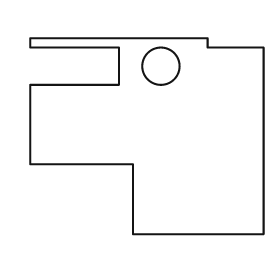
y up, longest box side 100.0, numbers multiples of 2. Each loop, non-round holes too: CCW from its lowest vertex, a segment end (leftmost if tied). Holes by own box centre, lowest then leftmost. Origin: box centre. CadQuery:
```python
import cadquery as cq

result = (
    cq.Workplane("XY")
    .moveTo(-6.0, -42.0)
    .lineTo(50.0, -42.0)
    .lineTo(50.0, 38.0)
    .lineTo(26.0, 38.0)
    .lineTo(26.0, 42.0)
    .lineTo(-50.0, 42.0)
    .lineTo(-50.0, 38.0)
    .lineTo(-12.0, 38.0)
    .lineTo(-12.0, 22.0)
    .lineTo(-50.0, 22.0)
    .lineTo(-50.0, -12.0)
    .lineTo(-6.0, -12.0)
    .close()
    .moveTo(6.0, 30.0)
    .circle(8.0)
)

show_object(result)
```